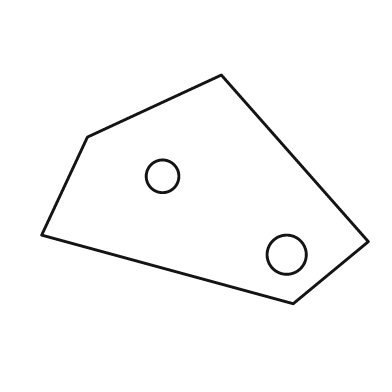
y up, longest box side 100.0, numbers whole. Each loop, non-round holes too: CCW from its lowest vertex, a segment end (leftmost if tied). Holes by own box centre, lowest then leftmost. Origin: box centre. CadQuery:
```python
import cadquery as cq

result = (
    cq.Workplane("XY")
    .moveTo(27.0, -35.0)
    .lineTo(50.0, -16.0)
    .lineTo(5.0, 35.0)
    .lineTo(-36.0, 16.0)
    .lineTo(-50.0, -14.0)
    .close()
    .moveTo(25.0, -20.0)
    .circle(6.0)
    .moveTo(-13.0, 4.0)
    .circle(5.0)
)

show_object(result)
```